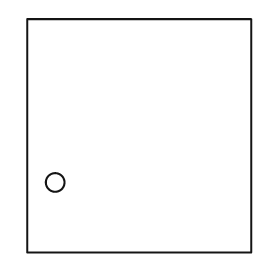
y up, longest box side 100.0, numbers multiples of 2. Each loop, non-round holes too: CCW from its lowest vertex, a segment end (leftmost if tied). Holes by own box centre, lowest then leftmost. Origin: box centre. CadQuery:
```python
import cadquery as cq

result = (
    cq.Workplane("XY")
    .moveTo(-48.0, -50.0)
    .lineTo(48.0, -50.0)
    .lineTo(48.0, 50.0)
    .lineTo(-48.0, 50.0)
    .close()
    .moveTo(-36.0, -20.0)
    .circle(4.0)
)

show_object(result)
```